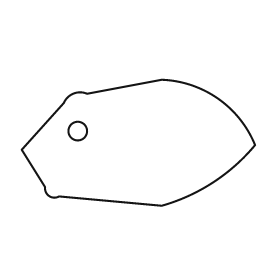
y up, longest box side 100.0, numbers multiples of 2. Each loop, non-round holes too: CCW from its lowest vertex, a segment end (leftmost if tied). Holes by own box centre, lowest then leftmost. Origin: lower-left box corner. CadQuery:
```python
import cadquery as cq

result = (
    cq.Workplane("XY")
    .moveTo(60.0, 0.0)
    .threePointArc((82.0, 10.0), (100.0, 26.0))
    .threePointArc((84.0, 46.0), (60.0, 54.0))
    .lineTo(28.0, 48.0)
    .threePointArc((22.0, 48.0), (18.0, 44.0))
    .lineTo(0.0, 24.0)
    .lineTo(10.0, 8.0)
    .threePointArc((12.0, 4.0), (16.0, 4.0))
    .close()
    .moveTo(24.0, 32.0)
    .circle(4.0)
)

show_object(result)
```